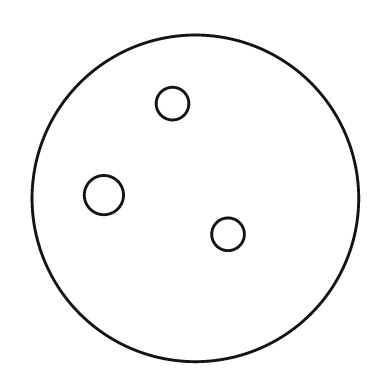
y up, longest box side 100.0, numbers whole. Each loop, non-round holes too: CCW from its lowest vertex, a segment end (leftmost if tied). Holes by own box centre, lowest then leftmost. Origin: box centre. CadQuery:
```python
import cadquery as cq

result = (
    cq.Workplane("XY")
    .moveTo(0.0, 0.0)
    .circle(50.0)
    .moveTo(10.0, -11.0)
    .circle(5.0)
    .moveTo(-28.0, 1.0)
    .circle(6.0)
    .moveTo(-7.0, 29.0)
    .circle(5.0)
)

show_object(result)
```